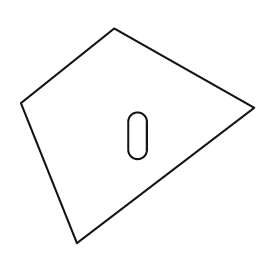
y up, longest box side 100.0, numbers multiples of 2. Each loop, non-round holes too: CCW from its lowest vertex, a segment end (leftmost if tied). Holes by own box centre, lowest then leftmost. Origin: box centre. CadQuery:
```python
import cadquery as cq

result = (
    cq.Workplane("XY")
    .moveTo(-26.0, -46.0)
    .lineTo(50.0, 12.0)
    .lineTo(-10.0, 46.0)
    .lineTo(-50.0, 14.0)
    .close()
    .moveTo(-4.0, -6.0)
    .threePointArc((0.0, -10.0), (4.0, -6.0))
    .lineTo(4.0, 6.0)
    .threePointArc((0.0, 10.0), (-4.0, 6.0))
    .close()
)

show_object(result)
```